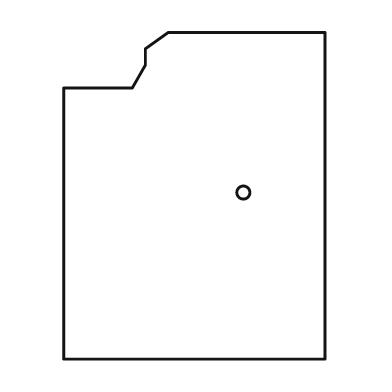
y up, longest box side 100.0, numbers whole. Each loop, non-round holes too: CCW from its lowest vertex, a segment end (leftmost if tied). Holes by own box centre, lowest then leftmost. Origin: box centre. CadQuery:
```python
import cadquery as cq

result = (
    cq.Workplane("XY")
    .moveTo(-40.0, -50.0)
    .lineTo(40.0, -50.0)
    .lineTo(40.0, 50.0)
    .lineTo(-8.0, 50.0)
    .lineTo(-15.0, 45.0)
    .lineTo(-15.0, 40.0)
    .lineTo(-19.0, 33.0)
    .lineTo(-40.0, 33.0)
    .close()
    .moveTo(15.0, 1.0)
    .circle(2.0)
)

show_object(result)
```